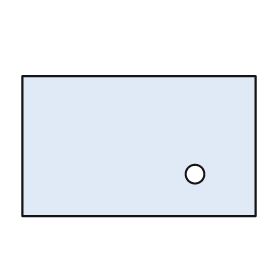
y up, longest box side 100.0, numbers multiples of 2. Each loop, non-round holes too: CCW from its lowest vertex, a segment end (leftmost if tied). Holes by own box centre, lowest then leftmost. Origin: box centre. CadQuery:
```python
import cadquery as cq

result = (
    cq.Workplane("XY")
    .moveTo(-50.0, -30.0)
    .lineTo(50.0, -30.0)
    .lineTo(50.0, 30.0)
    .lineTo(-50.0, 30.0)
    .close()
    .moveTo(24.0, -12.0)
    .circle(4.0)
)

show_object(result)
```